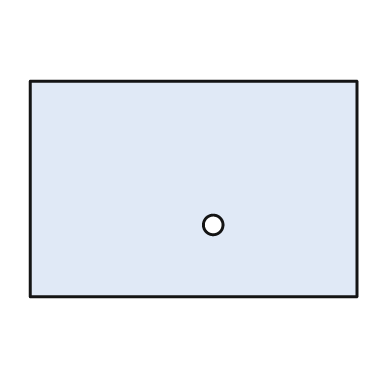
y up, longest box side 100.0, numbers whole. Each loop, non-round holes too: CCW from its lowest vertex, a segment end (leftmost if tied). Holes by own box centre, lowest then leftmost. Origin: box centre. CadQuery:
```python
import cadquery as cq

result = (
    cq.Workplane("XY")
    .moveTo(-50.0, -33.0)
    .lineTo(50.0, -33.0)
    .lineTo(50.0, 33.0)
    .lineTo(-50.0, 33.0)
    .close()
    .moveTo(6.0, -11.0)
    .circle(3.0)
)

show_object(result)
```